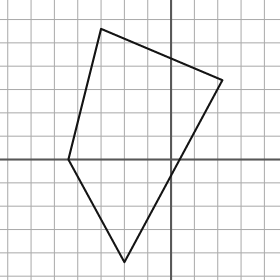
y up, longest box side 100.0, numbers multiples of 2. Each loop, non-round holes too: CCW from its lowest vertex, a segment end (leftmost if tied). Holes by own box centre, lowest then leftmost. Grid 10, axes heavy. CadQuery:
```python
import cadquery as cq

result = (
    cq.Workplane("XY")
    .moveTo(-20.0, -44.0)
    .lineTo(22.0, 34.0)
    .lineTo(-30.0, 56.0)
    .lineTo(-44.0, 0.0)
    .close()
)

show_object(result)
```